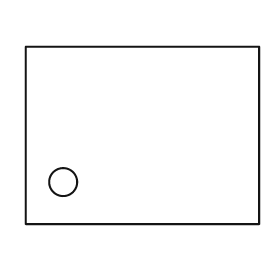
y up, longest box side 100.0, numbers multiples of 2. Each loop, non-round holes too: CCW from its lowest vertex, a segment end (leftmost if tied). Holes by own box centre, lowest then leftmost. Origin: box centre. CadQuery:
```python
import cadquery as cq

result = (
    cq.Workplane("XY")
    .moveTo(-50.0, -38.0)
    .lineTo(50.0, -38.0)
    .lineTo(50.0, 38.0)
    .lineTo(-50.0, 38.0)
    .close()
    .moveTo(-34.0, -20.0)
    .circle(6.0)
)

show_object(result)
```